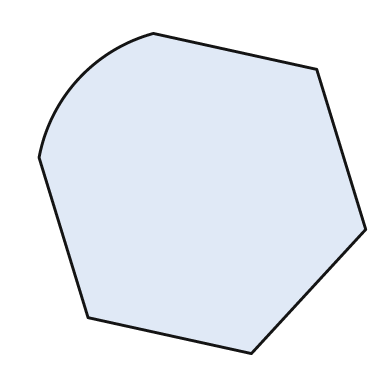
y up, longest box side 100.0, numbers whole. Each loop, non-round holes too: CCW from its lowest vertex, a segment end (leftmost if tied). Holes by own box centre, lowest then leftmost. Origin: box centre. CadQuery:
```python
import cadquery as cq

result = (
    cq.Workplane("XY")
    .moveTo(15.0, -49.0)
    .lineTo(50.0, -11.0)
    .lineTo(35.0, 38.0)
    .lineTo(-15.0, 49.0)
    .threePointArc((-38.0, 35.0), (-50.0, 11.0))
    .lineTo(-35.0, -38.0)
    .close()
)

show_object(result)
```